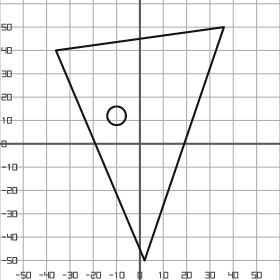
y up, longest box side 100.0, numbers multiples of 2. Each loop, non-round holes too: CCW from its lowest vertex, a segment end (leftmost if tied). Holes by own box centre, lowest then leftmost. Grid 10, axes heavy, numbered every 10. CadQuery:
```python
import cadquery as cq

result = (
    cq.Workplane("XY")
    .moveTo(2.0, -50.0)
    .lineTo(36.0, 50.0)
    .lineTo(-36.0, 40.0)
    .close()
    .moveTo(-10.0, 12.0)
    .circle(4.0)
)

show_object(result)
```